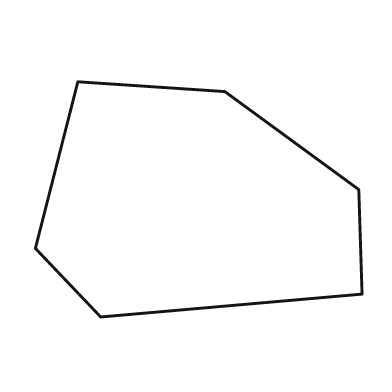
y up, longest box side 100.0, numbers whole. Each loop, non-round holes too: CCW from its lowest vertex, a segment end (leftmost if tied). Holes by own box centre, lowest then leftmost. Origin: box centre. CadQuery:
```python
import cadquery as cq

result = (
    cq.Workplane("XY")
    .moveTo(-30.0, -36.0)
    .lineTo(50.0, -29.0)
    .lineTo(49.0, 3.0)
    .lineTo(8.0, 33.0)
    .lineTo(-37.0, 36.0)
    .lineTo(-50.0, -15.0)
    .close()
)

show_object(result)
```